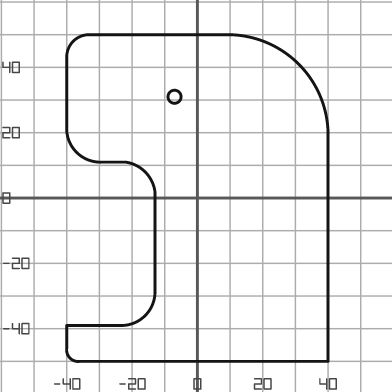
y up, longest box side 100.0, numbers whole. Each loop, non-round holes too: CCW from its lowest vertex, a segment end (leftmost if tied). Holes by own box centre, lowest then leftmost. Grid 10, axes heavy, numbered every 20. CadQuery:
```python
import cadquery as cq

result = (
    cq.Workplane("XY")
    .moveTo(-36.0, -50.0)
    .lineTo(40.0, -50.0)
    .lineTo(40.0, 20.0)
    .threePointArc((31.0, 41.0), (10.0, 50.0))
    .lineTo(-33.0, 50.0)
    .threePointArc((-38.0, 48.0), (-40.0, 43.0))
    .lineTo(-40.0, 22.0)
    .threePointArc((-37.0, 14.0), (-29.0, 11.0))
    .lineTo(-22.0, 11.0)
    .threePointArc((-16.0, 8.0), (-13.0, 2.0))
    .lineTo(-13.0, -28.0)
    .threePointArc((-16.0, -36.0), (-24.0, -39.0))
    .lineTo(-40.0, -39.0)
    .lineTo(-40.0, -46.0)
    .threePointArc((-39.0, -49.0), (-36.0, -50.0))
    .close()
    .moveTo(-7.0, 31.0)
    .circle(2.0)
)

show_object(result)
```